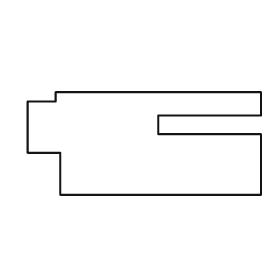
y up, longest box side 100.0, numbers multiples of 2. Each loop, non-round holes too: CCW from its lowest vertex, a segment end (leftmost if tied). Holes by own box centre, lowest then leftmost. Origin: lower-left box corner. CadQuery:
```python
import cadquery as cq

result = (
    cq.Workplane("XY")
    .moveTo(14.0, 0.0)
    .lineTo(100.0, 0.0)
    .lineTo(100.0, 26.0)
    .lineTo(56.0, 26.0)
    .lineTo(56.0, 34.0)
    .lineTo(100.0, 34.0)
    .lineTo(100.0, 44.0)
    .lineTo(12.0, 44.0)
    .lineTo(12.0, 40.0)
    .lineTo(0.0, 40.0)
    .lineTo(0.0, 18.0)
    .lineTo(14.0, 18.0)
    .close()
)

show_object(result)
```